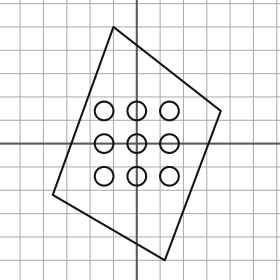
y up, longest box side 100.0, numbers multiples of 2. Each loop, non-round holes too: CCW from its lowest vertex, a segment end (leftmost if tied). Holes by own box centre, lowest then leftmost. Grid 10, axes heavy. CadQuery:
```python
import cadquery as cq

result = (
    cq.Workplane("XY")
    .moveTo(12.0, -50.0)
    .lineTo(36.0, 14.0)
    .lineTo(-10.0, 50.0)
    .lineTo(-36.0, -22.0)
    .close()
    .moveTo(-14.0, -14.0)
    .circle(4.0)
    .moveTo(0.0, -14.0)
    .circle(4.0)
    .moveTo(14.0, -14.0)
    .circle(4.0)
    .moveTo(-14.0, 0.0)
    .circle(4.0)
    .moveTo(0.0, 0.0)
    .circle(4.0)
    .moveTo(14.0, 0.0)
    .circle(4.0)
    .moveTo(-14.0, 14.0)
    .circle(4.0)
    .moveTo(0.0, 14.0)
    .circle(4.0)
    .moveTo(14.0, 14.0)
    .circle(4.0)
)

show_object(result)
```